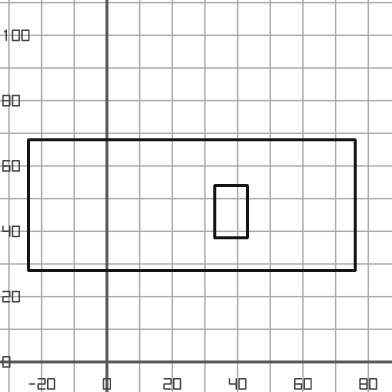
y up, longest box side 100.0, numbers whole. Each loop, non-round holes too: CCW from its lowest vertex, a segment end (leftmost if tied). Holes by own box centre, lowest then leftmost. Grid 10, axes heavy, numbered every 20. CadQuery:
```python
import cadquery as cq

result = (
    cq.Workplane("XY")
    .moveTo(-24.0, 28.0)
    .lineTo(76.0, 28.0)
    .lineTo(76.0, 68.0)
    .lineTo(-24.0, 68.0)
    .close()
    .moveTo(33.0, 38.0)
    .lineTo(43.0, 38.0)
    .lineTo(43.0, 54.0)
    .lineTo(33.0, 54.0)
    .close()
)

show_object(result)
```